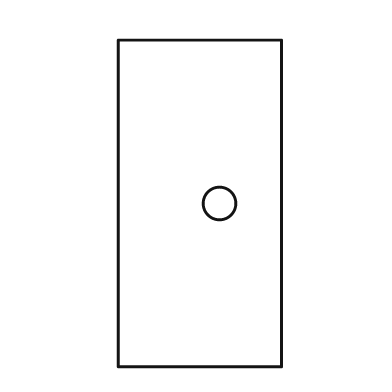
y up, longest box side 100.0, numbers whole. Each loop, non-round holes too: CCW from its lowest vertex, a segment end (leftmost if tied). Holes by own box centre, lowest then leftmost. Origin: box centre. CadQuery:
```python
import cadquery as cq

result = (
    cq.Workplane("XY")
    .moveTo(-25.0, -50.0)
    .lineTo(25.0, -50.0)
    .lineTo(25.0, 50.0)
    .lineTo(-25.0, 50.0)
    .close()
    .moveTo(6.0, 0.0)
    .circle(5.0)
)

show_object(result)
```